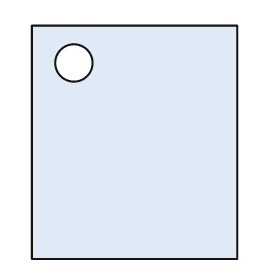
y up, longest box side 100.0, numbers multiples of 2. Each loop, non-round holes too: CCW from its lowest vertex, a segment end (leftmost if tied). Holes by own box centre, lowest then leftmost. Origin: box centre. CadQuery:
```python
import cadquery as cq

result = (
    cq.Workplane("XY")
    .moveTo(-44.0, -50.0)
    .lineTo(44.0, -50.0)
    .lineTo(44.0, 50.0)
    .lineTo(-44.0, 50.0)
    .close()
    .moveTo(-26.0, 34.0)
    .circle(8.0)
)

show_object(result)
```